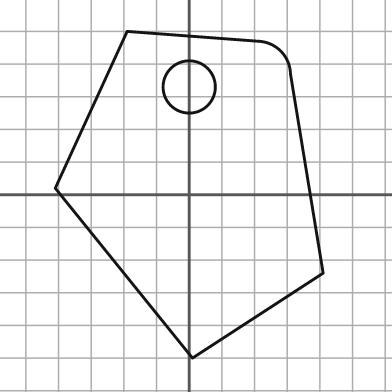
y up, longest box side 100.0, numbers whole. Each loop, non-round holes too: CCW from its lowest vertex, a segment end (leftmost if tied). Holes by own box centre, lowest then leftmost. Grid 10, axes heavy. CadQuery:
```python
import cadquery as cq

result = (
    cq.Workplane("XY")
    .moveTo(1.0, -50.0)
    .lineTo(41.0, -24.0)
    .lineTo(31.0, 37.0)
    .threePointArc((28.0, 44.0), (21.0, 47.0))
    .lineTo(-19.0, 50.0)
    .lineTo(-41.0, 2.0)
    .close()
    .moveTo(0.0, 33.0)
    .circle(8.0)
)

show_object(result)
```